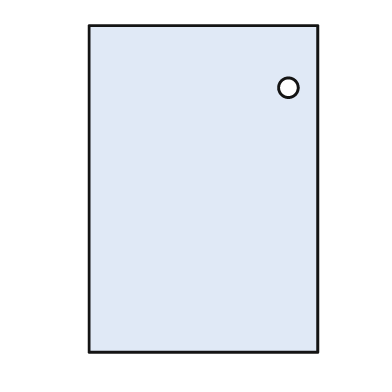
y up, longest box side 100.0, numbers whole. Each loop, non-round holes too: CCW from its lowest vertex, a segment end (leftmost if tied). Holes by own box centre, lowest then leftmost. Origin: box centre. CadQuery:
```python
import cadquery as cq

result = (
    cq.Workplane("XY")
    .moveTo(-35.0, -50.0)
    .lineTo(35.0, -50.0)
    .lineTo(35.0, 50.0)
    .lineTo(-35.0, 50.0)
    .close()
    .moveTo(26.0, 31.0)
    .circle(3.0)
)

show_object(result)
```